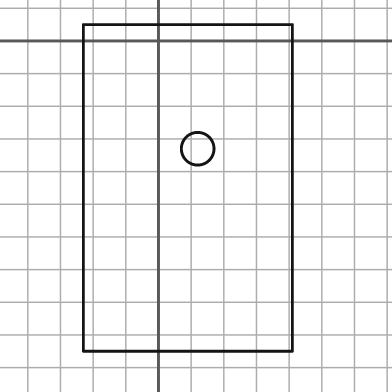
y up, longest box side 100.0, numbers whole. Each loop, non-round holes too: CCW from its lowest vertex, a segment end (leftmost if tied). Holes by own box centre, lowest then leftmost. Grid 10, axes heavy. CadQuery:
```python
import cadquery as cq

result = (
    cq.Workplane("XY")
    .moveTo(-23.0, -95.0)
    .lineTo(41.0, -95.0)
    .lineTo(41.0, 5.0)
    .lineTo(-23.0, 5.0)
    .close()
    .moveTo(12.0, -33.0)
    .circle(5.0)
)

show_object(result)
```